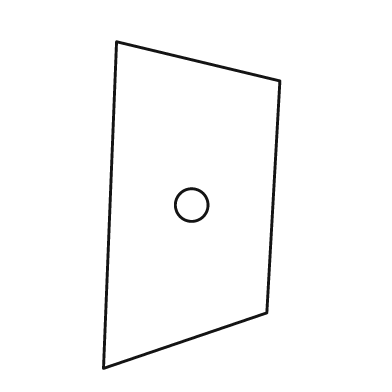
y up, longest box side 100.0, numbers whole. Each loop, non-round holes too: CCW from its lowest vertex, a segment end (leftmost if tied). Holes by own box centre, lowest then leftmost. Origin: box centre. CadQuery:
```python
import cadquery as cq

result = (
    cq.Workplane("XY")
    .moveTo(-27.0, -50.0)
    .lineTo(23.0, -33.0)
    .lineTo(27.0, 38.0)
    .lineTo(-23.0, 50.0)
    .close()
    .moveTo(0.0, 0.0)
    .circle(5.0)
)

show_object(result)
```